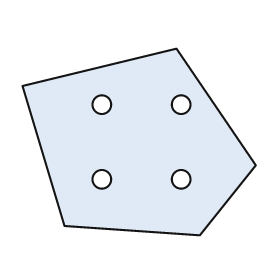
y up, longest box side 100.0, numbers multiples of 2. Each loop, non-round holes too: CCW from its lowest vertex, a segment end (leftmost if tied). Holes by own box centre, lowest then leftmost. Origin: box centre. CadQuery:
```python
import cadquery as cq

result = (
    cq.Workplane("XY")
    .moveTo(26.0, -40.0)
    .lineTo(50.0, -10.0)
    .lineTo(16.0, 40.0)
    .lineTo(-50.0, 24.0)
    .lineTo(-32.0, -36.0)
    .close()
    .moveTo(-16.0, -16.0)
    .circle(4.0)
    .moveTo(18.0, -16.0)
    .circle(4.0)
    .moveTo(-16.0, 16.0)
    .circle(4.0)
    .moveTo(18.0, 16.0)
    .circle(4.0)
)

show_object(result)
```